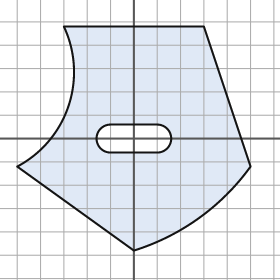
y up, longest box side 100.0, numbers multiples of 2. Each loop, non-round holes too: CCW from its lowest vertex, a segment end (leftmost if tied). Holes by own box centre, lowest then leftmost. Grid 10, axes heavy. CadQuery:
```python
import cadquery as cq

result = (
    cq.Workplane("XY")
    .moveTo(0.0, -48.0)
    .threePointArc((28.0, -34.0), (50.0, -12.0))
    .lineTo(30.0, 48.0)
    .lineTo(-30.0, 48.0)
    .threePointArc((-28.0, 14.0), (-50.0, -12.0))
    .close()
    .moveTo(-10.0, -6.0)
    .lineTo(10.0, -6.0)
    .threePointArc((16.0, 0.0), (10.0, 6.0))
    .lineTo(-10.0, 6.0)
    .threePointArc((-16.0, 0.0), (-10.0, -6.0))
    .close()
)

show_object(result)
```